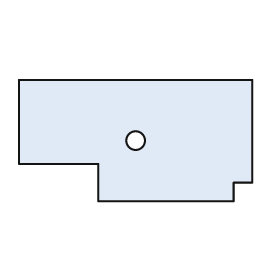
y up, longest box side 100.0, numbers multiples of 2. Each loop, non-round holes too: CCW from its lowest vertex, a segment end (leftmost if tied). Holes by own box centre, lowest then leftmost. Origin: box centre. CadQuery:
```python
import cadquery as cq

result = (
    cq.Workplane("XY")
    .moveTo(-16.0, -26.0)
    .lineTo(42.0, -26.0)
    .lineTo(42.0, -18.0)
    .lineTo(50.0, -18.0)
    .lineTo(50.0, 26.0)
    .lineTo(-50.0, 26.0)
    .lineTo(-50.0, -10.0)
    .lineTo(-16.0, -10.0)
    .close()
    .moveTo(0.0, 0.0)
    .circle(4.0)
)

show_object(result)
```